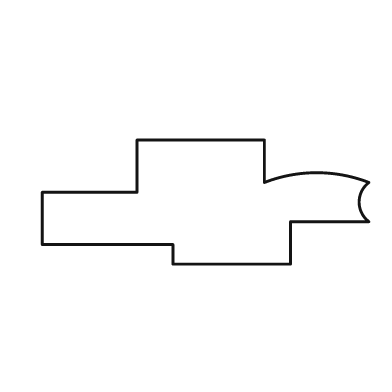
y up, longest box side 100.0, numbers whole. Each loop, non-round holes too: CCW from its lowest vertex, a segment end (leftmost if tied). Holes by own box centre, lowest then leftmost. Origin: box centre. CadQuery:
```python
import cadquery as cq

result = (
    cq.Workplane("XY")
    .moveTo(-10.0, -19.0)
    .lineTo(26.0, -19.0)
    .lineTo(26.0, -6.0)
    .lineTo(50.0, -6.0)
    .threePointArc((47.0, 0.0), (50.0, 6.0))
    .threePointArc((34.0, 9.0), (18.0, 6.0))
    .lineTo(18.0, 19.0)
    .lineTo(-21.0, 19.0)
    .lineTo(-21.0, 3.0)
    .lineTo(-50.0, 3.0)
    .lineTo(-50.0, -13.0)
    .lineTo(-10.0, -13.0)
    .close()
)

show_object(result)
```